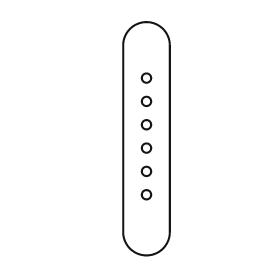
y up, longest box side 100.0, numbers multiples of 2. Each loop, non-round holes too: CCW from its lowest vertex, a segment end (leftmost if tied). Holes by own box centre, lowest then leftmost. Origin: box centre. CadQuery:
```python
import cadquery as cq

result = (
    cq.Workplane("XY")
    .moveTo(-10.0, -40.0)
    .threePointArc((0.0, -50.0), (10.0, -40.0))
    .lineTo(10.0, 40.0)
    .threePointArc((0.0, 50.0), (-10.0, 40.0))
    .close()
    .moveTo(0.0, -24.0)
    .circle(2.0)
    .moveTo(0.0, -14.0)
    .circle(2.0)
    .moveTo(0.0, -4.0)
    .circle(2.0)
    .moveTo(0.0, 6.0)
    .circle(2.0)
    .moveTo(0.0, 16.0)
    .circle(2.0)
    .moveTo(0.0, 26.0)
    .circle(2.0)
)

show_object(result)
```